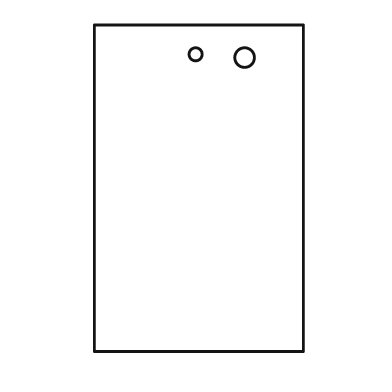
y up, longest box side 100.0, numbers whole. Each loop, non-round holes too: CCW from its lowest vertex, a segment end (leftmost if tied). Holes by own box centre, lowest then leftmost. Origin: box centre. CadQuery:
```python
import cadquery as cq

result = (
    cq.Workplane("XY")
    .moveTo(-32.0, -50.0)
    .lineTo(32.0, -50.0)
    .lineTo(32.0, 50.0)
    .lineTo(-32.0, 50.0)
    .close()
    .moveTo(14.0, 40.0)
    .circle(3.0)
    .moveTo(-1.0, 41.0)
    .circle(2.0)
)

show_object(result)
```